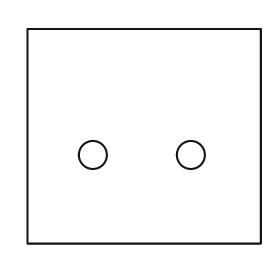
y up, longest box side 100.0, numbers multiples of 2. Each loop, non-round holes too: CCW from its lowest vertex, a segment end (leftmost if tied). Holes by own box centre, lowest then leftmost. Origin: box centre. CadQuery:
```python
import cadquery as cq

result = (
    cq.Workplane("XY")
    .moveTo(-50.0, -46.0)
    .lineTo(50.0, -46.0)
    .lineTo(50.0, 46.0)
    .lineTo(-50.0, 46.0)
    .close()
    .moveTo(-22.0, -8.0)
    .circle(6.0)
    .moveTo(20.0, -8.0)
    .circle(6.0)
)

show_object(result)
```